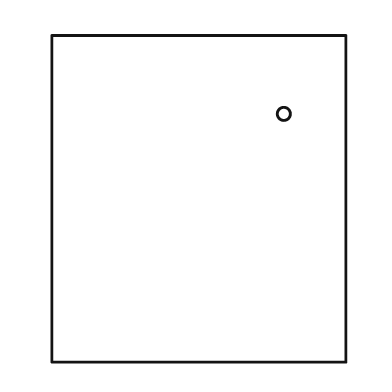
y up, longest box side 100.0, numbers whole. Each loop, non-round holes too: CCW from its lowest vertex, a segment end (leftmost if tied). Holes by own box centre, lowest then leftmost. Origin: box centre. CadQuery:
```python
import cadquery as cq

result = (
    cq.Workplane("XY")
    .moveTo(-45.0, -50.0)
    .lineTo(45.0, -50.0)
    .lineTo(45.0, 50.0)
    .lineTo(-45.0, 50.0)
    .close()
    .moveTo(26.0, 26.0)
    .circle(2.0)
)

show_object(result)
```